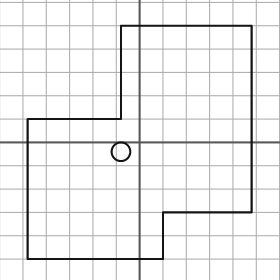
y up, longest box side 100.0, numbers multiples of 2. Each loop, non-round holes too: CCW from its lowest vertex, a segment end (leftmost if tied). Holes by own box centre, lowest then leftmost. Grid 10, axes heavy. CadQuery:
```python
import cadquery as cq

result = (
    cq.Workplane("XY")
    .moveTo(-48.0, -50.0)
    .lineTo(10.0, -50.0)
    .lineTo(10.0, -30.0)
    .lineTo(48.0, -30.0)
    .lineTo(48.0, 50.0)
    .lineTo(-8.0, 50.0)
    .lineTo(-8.0, 10.0)
    .lineTo(-48.0, 10.0)
    .close()
    .moveTo(-8.0, -4.0)
    .circle(4.0)
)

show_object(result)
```